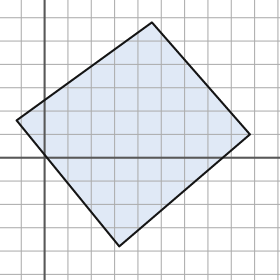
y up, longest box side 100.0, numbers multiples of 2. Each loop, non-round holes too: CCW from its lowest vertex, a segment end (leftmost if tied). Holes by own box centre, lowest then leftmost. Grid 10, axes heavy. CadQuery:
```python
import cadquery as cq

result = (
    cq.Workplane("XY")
    .moveTo(32.0, -38.0)
    .lineTo(88.0, 10.0)
    .lineTo(46.0, 58.0)
    .lineTo(-12.0, 16.0)
    .close()
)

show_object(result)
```